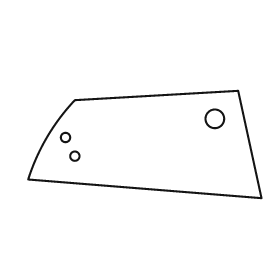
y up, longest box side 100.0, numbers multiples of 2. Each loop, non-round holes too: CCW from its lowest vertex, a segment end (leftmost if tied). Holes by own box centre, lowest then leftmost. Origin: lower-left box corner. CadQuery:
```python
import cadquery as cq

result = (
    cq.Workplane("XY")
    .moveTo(100.0, 0.0)
    .lineTo(90.0, 46.0)
    .lineTo(20.0, 42.0)
    .threePointArc((8.0, 26.0), (0.0, 8.0))
    .close()
    .moveTo(20.0, 18.0)
    .circle(2.0)
    .moveTo(16.0, 26.0)
    .circle(2.0)
    .moveTo(80.0, 34.0)
    .circle(4.0)
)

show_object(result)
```